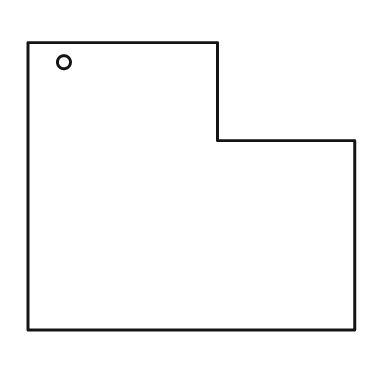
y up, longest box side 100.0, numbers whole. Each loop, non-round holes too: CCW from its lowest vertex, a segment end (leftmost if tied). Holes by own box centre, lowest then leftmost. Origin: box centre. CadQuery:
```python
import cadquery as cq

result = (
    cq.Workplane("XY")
    .moveTo(-50.0, -44.0)
    .lineTo(50.0, -44.0)
    .lineTo(50.0, 14.0)
    .lineTo(8.0, 14.0)
    .lineTo(8.0, 44.0)
    .lineTo(-50.0, 44.0)
    .close()
    .moveTo(-39.0, 38.0)
    .circle(2.0)
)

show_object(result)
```